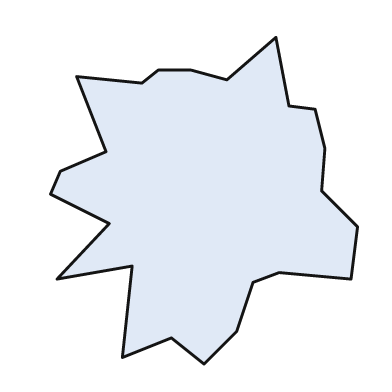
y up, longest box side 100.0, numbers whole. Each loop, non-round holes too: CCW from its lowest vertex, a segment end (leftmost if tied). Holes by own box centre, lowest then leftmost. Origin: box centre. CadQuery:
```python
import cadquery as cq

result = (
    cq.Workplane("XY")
    .moveTo(0.0, -50.0)
    .lineTo(10.0, -40.0)
    .lineTo(15.0, -25.0)
    .lineTo(23.0, -22.0)
    .lineTo(45.0, -24.0)
    .lineTo(47.0, -8.0)
    .lineTo(36.0, 3.0)
    .lineTo(37.0, 16.0)
    .lineTo(34.0, 28.0)
    .lineTo(26.0, 29.0)
    .lineTo(22.0, 50.0)
    .lineTo(7.0, 37.0)
    .lineTo(-4.0, 40.0)
    .lineTo(-14.0, 40.0)
    .lineTo(-19.0, 36.0)
    .lineTo(-39.0, 38.0)
    .lineTo(-30.0, 15.0)
    .lineTo(-44.0, 9.0)
    .lineTo(-47.0, 2.0)
    .lineTo(-29.0, -7.0)
    .lineTo(-45.0, -24.0)
    .lineTo(-22.0, -20.0)
    .lineTo(-25.0, -48.0)
    .lineTo(-10.0, -42.0)
    .close()
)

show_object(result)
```